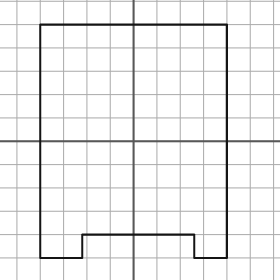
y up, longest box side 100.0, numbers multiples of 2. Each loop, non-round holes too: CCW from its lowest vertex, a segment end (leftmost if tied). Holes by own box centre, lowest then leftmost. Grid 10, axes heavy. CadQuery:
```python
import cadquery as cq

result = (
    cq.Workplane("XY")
    .moveTo(-40.0, -50.0)
    .lineTo(-22.0, -50.0)
    .lineTo(-22.0, -40.0)
    .lineTo(26.0, -40.0)
    .lineTo(26.0, -50.0)
    .lineTo(40.0, -50.0)
    .lineTo(40.0, 50.0)
    .lineTo(-40.0, 50.0)
    .close()
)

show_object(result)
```